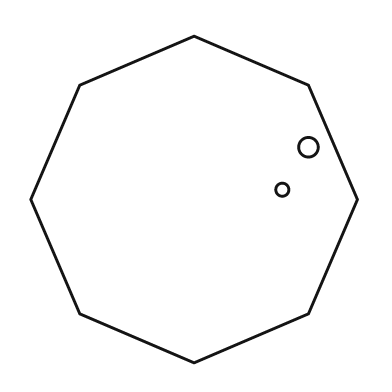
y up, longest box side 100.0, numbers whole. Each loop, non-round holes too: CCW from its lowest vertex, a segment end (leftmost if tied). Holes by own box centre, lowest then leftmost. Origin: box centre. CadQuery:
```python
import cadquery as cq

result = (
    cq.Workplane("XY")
    .moveTo(0.0, -50.0)
    .lineTo(35.0, -35.0)
    .lineTo(50.0, 0.0)
    .lineTo(35.0, 35.0)
    .lineTo(0.0, 50.0)
    .lineTo(-35.0, 35.0)
    .lineTo(-50.0, 0.0)
    .lineTo(-35.0, -35.0)
    .close()
    .moveTo(27.0, 3.0)
    .circle(2.0)
    .moveTo(35.0, 16.0)
    .circle(3.0)
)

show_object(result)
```